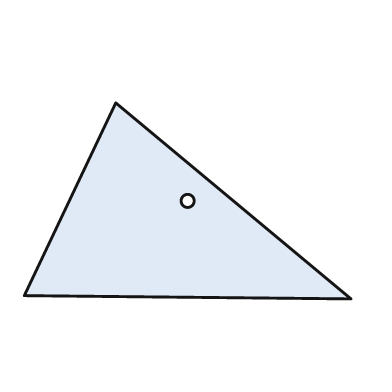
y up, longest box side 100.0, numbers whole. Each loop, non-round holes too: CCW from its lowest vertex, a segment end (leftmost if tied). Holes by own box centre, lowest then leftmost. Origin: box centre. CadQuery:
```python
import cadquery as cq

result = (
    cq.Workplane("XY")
    .moveTo(50.0, -30.0)
    .lineTo(-22.0, 30.0)
    .lineTo(-50.0, -29.0)
    .close()
    .moveTo(0.0, 0.0)
    .circle(2.0)
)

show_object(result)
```